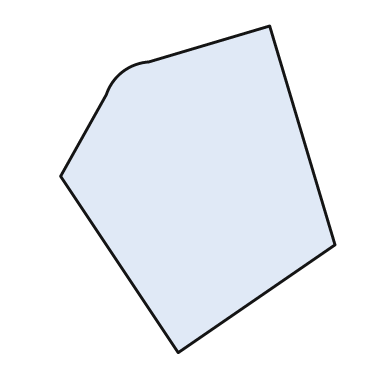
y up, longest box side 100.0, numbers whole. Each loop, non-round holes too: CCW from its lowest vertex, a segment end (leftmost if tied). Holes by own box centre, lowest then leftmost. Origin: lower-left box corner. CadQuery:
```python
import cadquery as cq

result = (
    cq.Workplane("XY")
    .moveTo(36.0, 0.0)
    .lineTo(84.0, 33.0)
    .lineTo(64.0, 100.0)
    .lineTo(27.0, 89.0)
    .threePointArc((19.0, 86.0), (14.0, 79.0))
    .lineTo(0.0, 54.0)
    .close()
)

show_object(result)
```